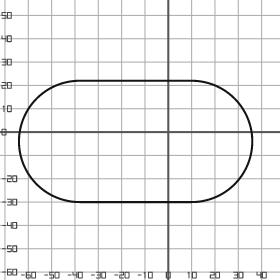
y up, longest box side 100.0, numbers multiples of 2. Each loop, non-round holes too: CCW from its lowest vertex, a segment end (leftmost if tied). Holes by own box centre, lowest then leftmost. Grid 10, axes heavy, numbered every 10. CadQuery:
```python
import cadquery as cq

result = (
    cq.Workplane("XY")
    .moveTo(-38.0, -30.0)
    .lineTo(10.0, -30.0)
    .threePointArc((36.0, -4.0), (10.0, 22.0))
    .lineTo(-38.0, 22.0)
    .threePointArc((-64.0, -4.0), (-38.0, -30.0))
    .close()
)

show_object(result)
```